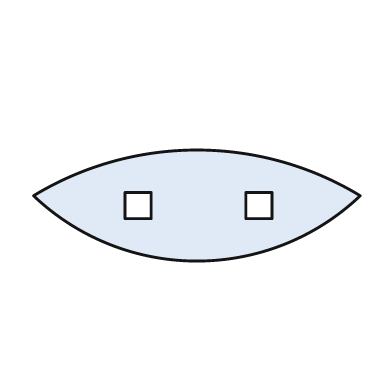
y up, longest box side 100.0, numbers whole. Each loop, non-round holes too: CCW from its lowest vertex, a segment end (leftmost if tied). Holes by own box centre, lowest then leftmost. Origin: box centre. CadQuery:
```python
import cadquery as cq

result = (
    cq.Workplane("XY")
    .moveTo(-50.0, 3.0)
    .threePointArc((0.0, -17.0), (50.0, 3.0))
    .threePointArc((0.0, 17.0), (-50.0, 3.0))
    .close()
    .moveTo(-22.0, -4.0)
    .lineTo(-14.0, -4.0)
    .lineTo(-14.0, 4.0)
    .lineTo(-22.0, 4.0)
    .close()
    .moveTo(15.0, -4.0)
    .lineTo(23.0, -4.0)
    .lineTo(23.0, 4.0)
    .lineTo(15.0, 4.0)
    .close()
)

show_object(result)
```